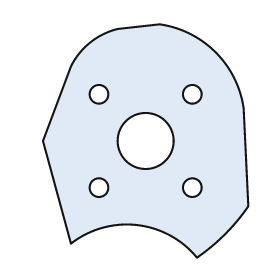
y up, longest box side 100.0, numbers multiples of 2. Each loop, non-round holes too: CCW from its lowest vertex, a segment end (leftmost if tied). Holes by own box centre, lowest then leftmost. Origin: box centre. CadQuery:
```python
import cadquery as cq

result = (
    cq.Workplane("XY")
    .moveTo(22.0, -50.0)
    .threePointArc((34.0, -40.0), (44.0, -28.0))
    .lineTo(42.0, 14.0)
    .threePointArc((30.0, 38.0), (6.0, 50.0))
    .lineTo(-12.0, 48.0)
    .threePointArc((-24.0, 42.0), (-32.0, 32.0))
    .lineTo(-44.0, 0.0)
    .lineTo(-32.0, -44.0)
    .threePointArc((-4.0, -36.0), (22.0, -50.0))
    .close()
    .moveTo(-20.0, -20.0)
    .circle(4.0)
    .moveTo(20.0, -20.0)
    .circle(4.0)
    .moveTo(0.0, 0.0)
    .circle(12.0)
    .moveTo(-20.0, 20.0)
    .circle(4.0)
    .moveTo(20.0, 20.0)
    .circle(4.0)
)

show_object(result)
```